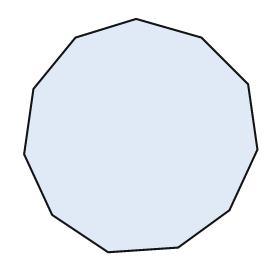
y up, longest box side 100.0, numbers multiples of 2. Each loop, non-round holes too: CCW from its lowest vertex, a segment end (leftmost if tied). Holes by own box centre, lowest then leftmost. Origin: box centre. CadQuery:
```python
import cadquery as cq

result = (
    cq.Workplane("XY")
    .moveTo(-14.0, -50.0)
    .lineTo(16.0, -48.0)
    .lineTo(38.0, -32.0)
    .lineTo(50.0, -6.0)
    .lineTo(46.0, 22.0)
    .lineTo(26.0, 42.0)
    .lineTo(-2.0, 50.0)
    .lineTo(-28.0, 42.0)
    .lineTo(-46.0, 20.0)
    .lineTo(-50.0, -8.0)
    .lineTo(-38.0, -34.0)
    .close()
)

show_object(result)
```